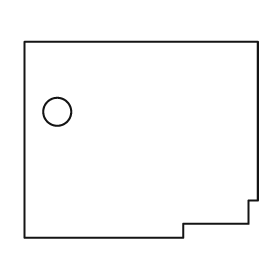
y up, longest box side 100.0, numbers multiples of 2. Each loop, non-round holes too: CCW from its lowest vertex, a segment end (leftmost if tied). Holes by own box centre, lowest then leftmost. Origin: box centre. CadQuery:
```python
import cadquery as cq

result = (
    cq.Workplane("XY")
    .moveTo(-50.0, -42.0)
    .lineTo(18.0, -42.0)
    .lineTo(18.0, -36.0)
    .lineTo(46.0, -36.0)
    .lineTo(46.0, -26.0)
    .lineTo(50.0, -26.0)
    .lineTo(50.0, 42.0)
    .lineTo(-50.0, 42.0)
    .close()
    .moveTo(-36.0, 12.0)
    .circle(6.0)
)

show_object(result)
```